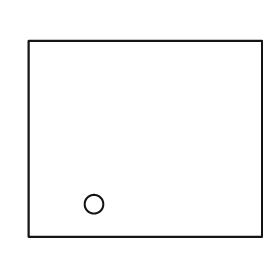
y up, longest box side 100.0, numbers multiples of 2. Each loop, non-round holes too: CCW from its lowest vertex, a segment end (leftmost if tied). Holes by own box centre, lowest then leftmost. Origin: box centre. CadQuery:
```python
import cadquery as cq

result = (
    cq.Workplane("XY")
    .moveTo(-50.0, -42.0)
    .lineTo(50.0, -42.0)
    .lineTo(50.0, 42.0)
    .lineTo(-50.0, 42.0)
    .close()
    .moveTo(-22.0, -28.0)
    .circle(4.0)
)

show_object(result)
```